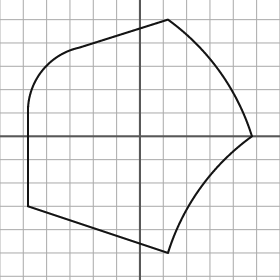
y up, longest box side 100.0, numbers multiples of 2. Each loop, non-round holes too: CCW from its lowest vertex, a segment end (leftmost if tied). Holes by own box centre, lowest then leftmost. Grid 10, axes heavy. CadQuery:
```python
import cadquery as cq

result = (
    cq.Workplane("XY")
    .moveTo(12.0, -50.0)
    .threePointArc((26.0, -22.0), (48.0, 0.0))
    .threePointArc((34.0, 28.0), (12.0, 50.0))
    .lineTo(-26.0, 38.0)
    .threePointArc((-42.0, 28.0), (-48.0, 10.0))
    .lineTo(-48.0, -30.0)
    .close()
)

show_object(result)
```